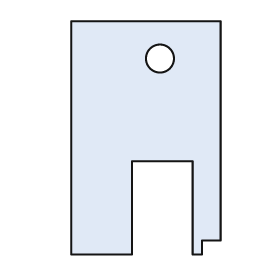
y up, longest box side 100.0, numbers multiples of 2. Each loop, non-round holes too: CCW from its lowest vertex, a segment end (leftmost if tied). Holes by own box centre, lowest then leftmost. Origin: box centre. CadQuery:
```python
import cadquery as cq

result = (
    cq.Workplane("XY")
    .moveTo(-32.0, -50.0)
    .lineTo(-6.0, -50.0)
    .lineTo(-6.0, -10.0)
    .lineTo(20.0, -10.0)
    .lineTo(20.0, -50.0)
    .lineTo(24.0, -50.0)
    .lineTo(24.0, -44.0)
    .lineTo(32.0, -44.0)
    .lineTo(32.0, 50.0)
    .lineTo(-32.0, 50.0)
    .close()
    .moveTo(6.0, 34.0)
    .circle(6.0)
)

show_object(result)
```